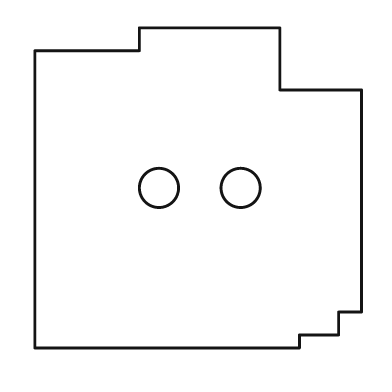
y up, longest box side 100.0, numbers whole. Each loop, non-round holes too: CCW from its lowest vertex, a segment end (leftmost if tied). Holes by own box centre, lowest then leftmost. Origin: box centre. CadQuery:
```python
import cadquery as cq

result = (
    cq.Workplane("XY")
    .moveTo(-50.0, -49.0)
    .lineTo(31.0, -49.0)
    .lineTo(31.0, -45.0)
    .lineTo(43.0, -45.0)
    .lineTo(43.0, -38.0)
    .lineTo(50.0, -38.0)
    .lineTo(50.0, 30.0)
    .lineTo(25.0, 30.0)
    .lineTo(25.0, 49.0)
    .lineTo(-18.0, 49.0)
    .lineTo(-18.0, 42.0)
    .lineTo(-50.0, 42.0)
    .close()
    .moveTo(-12.0, 0.0)
    .circle(6.0)
    .moveTo(13.0, 0.0)
    .circle(6.0)
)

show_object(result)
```